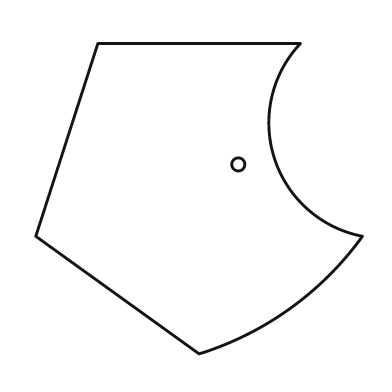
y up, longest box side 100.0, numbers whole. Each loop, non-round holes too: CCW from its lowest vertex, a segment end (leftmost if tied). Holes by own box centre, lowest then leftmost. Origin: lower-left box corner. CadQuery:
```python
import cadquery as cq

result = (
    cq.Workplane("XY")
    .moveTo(50.0, 0.0)
    .threePointArc((78.0, 14.0), (100.0, 36.0))
    .threePointArc((73.0, 60.0), (81.0, 95.0))
    .lineTo(19.0, 95.0)
    .lineTo(0.0, 36.0)
    .close()
    .moveTo(62.0, 58.0)
    .circle(2.0)
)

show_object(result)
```